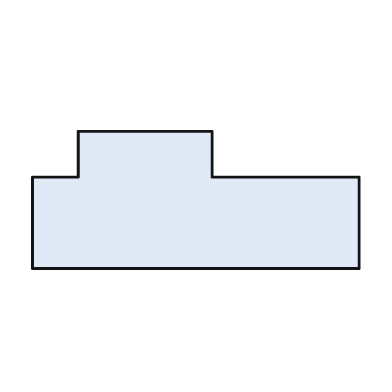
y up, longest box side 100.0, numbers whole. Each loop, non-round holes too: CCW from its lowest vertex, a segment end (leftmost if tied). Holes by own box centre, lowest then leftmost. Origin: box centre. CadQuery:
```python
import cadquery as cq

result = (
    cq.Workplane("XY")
    .moveTo(-50.0, -21.0)
    .lineTo(50.0, -21.0)
    .lineTo(50.0, 7.0)
    .lineTo(5.0, 7.0)
    .lineTo(5.0, 21.0)
    .lineTo(-36.0, 21.0)
    .lineTo(-36.0, 7.0)
    .lineTo(-50.0, 7.0)
    .close()
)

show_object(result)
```